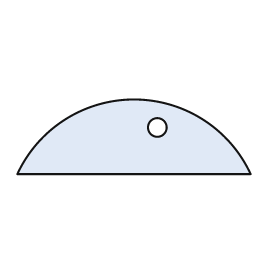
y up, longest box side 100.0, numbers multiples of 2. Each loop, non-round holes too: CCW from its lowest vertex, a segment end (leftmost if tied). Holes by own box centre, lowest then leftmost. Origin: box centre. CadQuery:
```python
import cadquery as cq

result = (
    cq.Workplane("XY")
    .moveTo(-50.0, -16.0)
    .lineTo(50.0, -16.0)
    .threePointArc((0.0, 16.0), (-50.0, -16.0))
    .close()
    .moveTo(10.0, 4.0)
    .circle(4.0)
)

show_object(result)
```